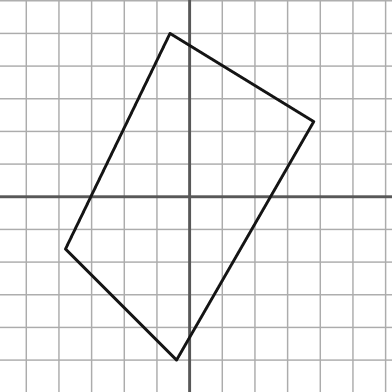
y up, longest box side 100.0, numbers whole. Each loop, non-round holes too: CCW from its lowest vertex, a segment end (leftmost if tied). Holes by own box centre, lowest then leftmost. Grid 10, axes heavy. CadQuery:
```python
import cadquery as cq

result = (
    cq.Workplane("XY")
    .moveTo(-4.0, -50.0)
    .lineTo(38.0, 23.0)
    .lineTo(-6.0, 50.0)
    .lineTo(-38.0, -16.0)
    .close()
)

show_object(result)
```